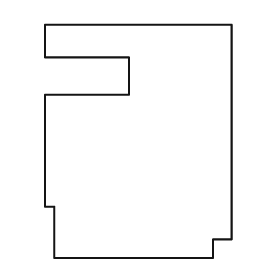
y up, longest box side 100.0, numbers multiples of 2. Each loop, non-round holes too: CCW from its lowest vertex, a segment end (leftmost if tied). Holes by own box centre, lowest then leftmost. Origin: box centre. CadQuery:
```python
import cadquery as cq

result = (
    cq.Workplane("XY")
    .moveTo(-36.0, -50.0)
    .lineTo(32.0, -50.0)
    .lineTo(32.0, -42.0)
    .lineTo(40.0, -42.0)
    .lineTo(40.0, 50.0)
    .lineTo(-40.0, 50.0)
    .lineTo(-40.0, 36.0)
    .lineTo(-4.0, 36.0)
    .lineTo(-4.0, 20.0)
    .lineTo(-40.0, 20.0)
    .lineTo(-40.0, -28.0)
    .lineTo(-36.0, -28.0)
    .close()
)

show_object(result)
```